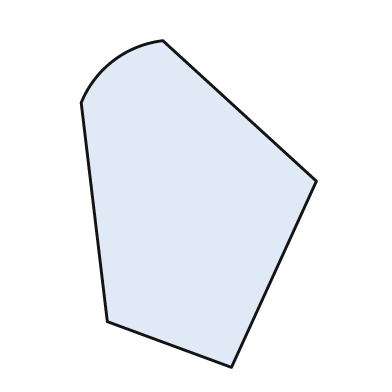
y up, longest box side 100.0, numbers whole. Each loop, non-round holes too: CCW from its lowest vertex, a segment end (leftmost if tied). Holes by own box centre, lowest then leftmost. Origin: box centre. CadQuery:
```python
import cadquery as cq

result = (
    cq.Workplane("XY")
    .moveTo(10.0, -50.0)
    .lineTo(36.0, 7.0)
    .lineTo(-11.0, 50.0)
    .threePointArc((-26.0, 44.0), (-36.0, 31.0))
    .lineTo(-28.0, -36.0)
    .close()
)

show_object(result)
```